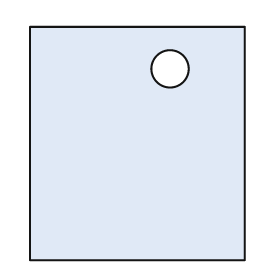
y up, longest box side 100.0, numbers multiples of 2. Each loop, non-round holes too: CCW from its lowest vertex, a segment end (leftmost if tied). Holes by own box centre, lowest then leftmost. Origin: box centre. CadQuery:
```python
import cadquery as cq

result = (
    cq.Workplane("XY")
    .moveTo(-46.0, -50.0)
    .lineTo(46.0, -50.0)
    .lineTo(46.0, 50.0)
    .lineTo(-46.0, 50.0)
    .close()
    .moveTo(14.0, 32.0)
    .circle(8.0)
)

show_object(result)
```